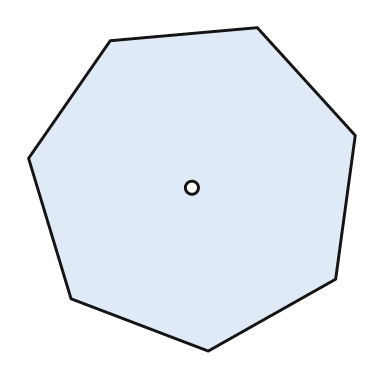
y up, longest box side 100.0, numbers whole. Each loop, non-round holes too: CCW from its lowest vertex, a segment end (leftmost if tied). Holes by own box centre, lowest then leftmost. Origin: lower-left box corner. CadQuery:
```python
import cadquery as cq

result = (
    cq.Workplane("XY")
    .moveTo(55.0, 0.0)
    .lineTo(94.0, 22.0)
    .lineTo(100.0, 66.0)
    .lineTo(70.0, 99.0)
    .lineTo(25.0, 95.0)
    .lineTo(0.0, 59.0)
    .lineTo(13.0, 16.0)
    .close()
    .moveTo(50.0, 50.0)
    .circle(2.0)
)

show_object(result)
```